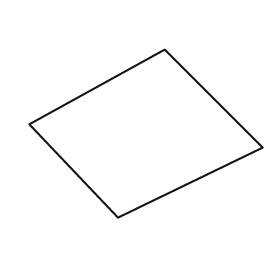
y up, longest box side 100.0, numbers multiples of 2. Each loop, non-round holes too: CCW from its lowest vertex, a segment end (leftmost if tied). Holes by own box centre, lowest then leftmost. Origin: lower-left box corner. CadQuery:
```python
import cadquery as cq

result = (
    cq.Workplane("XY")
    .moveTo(38.0, 0.0)
    .lineTo(100.0, 30.0)
    .lineTo(58.0, 72.0)
    .lineTo(0.0, 40.0)
    .close()
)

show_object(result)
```